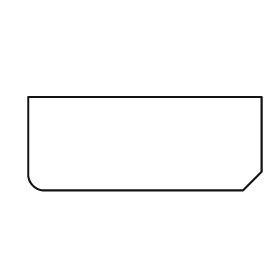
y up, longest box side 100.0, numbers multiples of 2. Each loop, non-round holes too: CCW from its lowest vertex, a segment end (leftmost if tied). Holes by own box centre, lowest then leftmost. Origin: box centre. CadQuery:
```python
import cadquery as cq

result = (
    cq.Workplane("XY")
    .moveTo(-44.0, -20.0)
    .lineTo(42.0, -20.0)
    .lineTo(50.0, -12.0)
    .lineTo(50.0, 20.0)
    .lineTo(-50.0, 20.0)
    .lineTo(-50.0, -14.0)
    .threePointArc((-48.0, -18.0), (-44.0, -20.0))
    .close()
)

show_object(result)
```